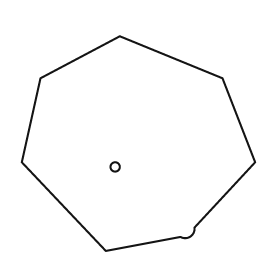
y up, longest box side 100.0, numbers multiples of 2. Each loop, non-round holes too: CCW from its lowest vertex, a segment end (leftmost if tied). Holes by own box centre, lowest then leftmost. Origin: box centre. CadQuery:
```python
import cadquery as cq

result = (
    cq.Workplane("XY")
    .moveTo(-14.0, -46.0)
    .lineTo(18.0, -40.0)
    .threePointArc((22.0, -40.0), (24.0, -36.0))
    .lineTo(50.0, -8.0)
    .lineTo(36.0, 28.0)
    .lineTo(-8.0, 46.0)
    .lineTo(-42.0, 28.0)
    .lineTo(-50.0, -8.0)
    .close()
    .moveTo(-10.0, -10.0)
    .circle(2.0)
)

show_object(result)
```